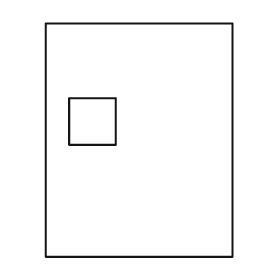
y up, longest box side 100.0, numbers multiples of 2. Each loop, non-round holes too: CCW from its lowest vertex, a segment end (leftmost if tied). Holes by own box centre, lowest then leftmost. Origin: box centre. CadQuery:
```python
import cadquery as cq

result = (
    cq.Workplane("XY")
    .moveTo(-40.0, -50.0)
    .lineTo(40.0, -50.0)
    .lineTo(40.0, 50.0)
    .lineTo(-40.0, 50.0)
    .close()
    .moveTo(-30.0, -2.0)
    .lineTo(-10.0, -2.0)
    .lineTo(-10.0, 18.0)
    .lineTo(-30.0, 18.0)
    .close()
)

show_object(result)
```